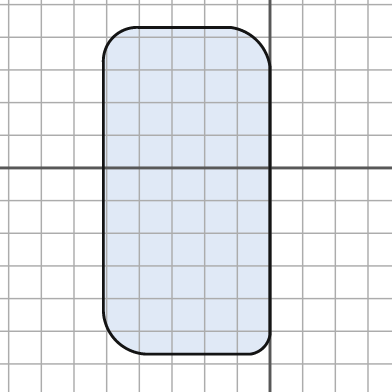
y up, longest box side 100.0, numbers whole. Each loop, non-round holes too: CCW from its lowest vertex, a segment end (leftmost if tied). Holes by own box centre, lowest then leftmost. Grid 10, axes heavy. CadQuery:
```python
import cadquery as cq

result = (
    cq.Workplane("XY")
    .moveTo(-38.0, -57.0)
    .lineTo(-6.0, -57.0)
    .threePointArc((-2.0, -55.0), (0.0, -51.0))
    .lineTo(0.0, 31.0)
    .threePointArc((-4.0, 39.0), (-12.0, 43.0))
    .lineTo(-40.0, 43.0)
    .threePointArc((-48.0, 40.0), (-51.0, 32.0))
    .lineTo(-51.0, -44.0)
    .threePointArc((-47.0, -53.0), (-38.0, -57.0))
    .close()
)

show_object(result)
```